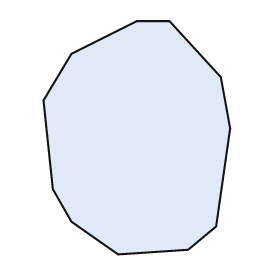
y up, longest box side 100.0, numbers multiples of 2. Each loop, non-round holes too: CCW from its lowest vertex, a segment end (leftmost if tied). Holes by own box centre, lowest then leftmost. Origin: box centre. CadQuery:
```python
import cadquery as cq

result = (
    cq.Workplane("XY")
    .moveTo(-8.0, -50.0)
    .lineTo(22.0, -48.0)
    .lineTo(34.0, -38.0)
    .lineTo(40.0, 4.0)
    .lineTo(36.0, 26.0)
    .lineTo(14.0, 50.0)
    .lineTo(0.0, 50.0)
    .lineTo(-28.0, 36.0)
    .lineTo(-40.0, 16.0)
    .lineTo(-36.0, -22.0)
    .lineTo(-28.0, -36.0)
    .close()
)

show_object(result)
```